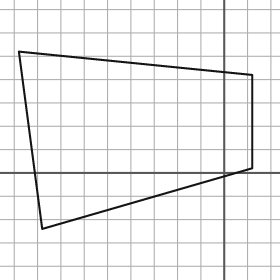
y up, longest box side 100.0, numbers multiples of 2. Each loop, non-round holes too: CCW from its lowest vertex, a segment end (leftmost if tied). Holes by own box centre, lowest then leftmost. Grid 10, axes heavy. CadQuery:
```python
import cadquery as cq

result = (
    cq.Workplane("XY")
    .moveTo(-78.0, -24.0)
    .lineTo(12.0, 2.0)
    .lineTo(12.0, 42.0)
    .lineTo(-88.0, 52.0)
    .close()
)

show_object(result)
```